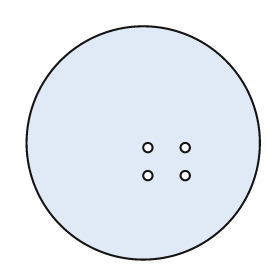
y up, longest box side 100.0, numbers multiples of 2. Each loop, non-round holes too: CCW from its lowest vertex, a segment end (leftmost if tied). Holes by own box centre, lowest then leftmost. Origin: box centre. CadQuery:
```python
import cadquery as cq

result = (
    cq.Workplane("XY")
    .moveTo(0.0, 0.0)
    .circle(50.0)
    .moveTo(2.0, -14.0)
    .circle(2.0)
    .moveTo(18.0, -14.0)
    .circle(2.0)
    .moveTo(2.0, -2.0)
    .circle(2.0)
    .moveTo(18.0, -2.0)
    .circle(2.0)
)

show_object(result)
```